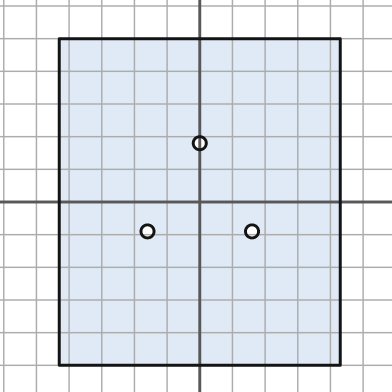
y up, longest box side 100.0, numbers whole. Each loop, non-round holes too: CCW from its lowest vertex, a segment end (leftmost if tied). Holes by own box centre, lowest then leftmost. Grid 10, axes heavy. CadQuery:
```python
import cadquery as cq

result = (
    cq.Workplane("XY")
    .moveTo(-43.0, -50.0)
    .lineTo(43.0, -50.0)
    .lineTo(43.0, 50.0)
    .lineTo(-43.0, 50.0)
    .close()
    .moveTo(-16.0, -9.0)
    .circle(2.0)
    .moveTo(16.0, -9.0)
    .circle(2.0)
    .moveTo(0.0, 18.0)
    .circle(2.0)
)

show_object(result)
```